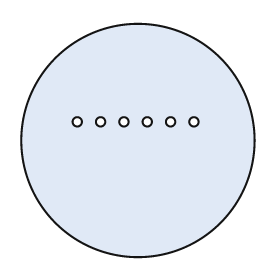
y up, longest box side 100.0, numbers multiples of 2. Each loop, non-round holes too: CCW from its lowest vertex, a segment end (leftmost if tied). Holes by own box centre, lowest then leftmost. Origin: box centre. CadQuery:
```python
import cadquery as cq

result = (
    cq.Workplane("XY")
    .moveTo(0.0, 0.0)
    .circle(50.0)
    .moveTo(-26.0, 8.0)
    .circle(2.0)
    .moveTo(-16.0, 8.0)
    .circle(2.0)
    .moveTo(-6.0, 8.0)
    .circle(2.0)
    .moveTo(4.0, 8.0)
    .circle(2.0)
    .moveTo(14.0, 8.0)
    .circle(2.0)
    .moveTo(24.0, 8.0)
    .circle(2.0)
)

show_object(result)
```